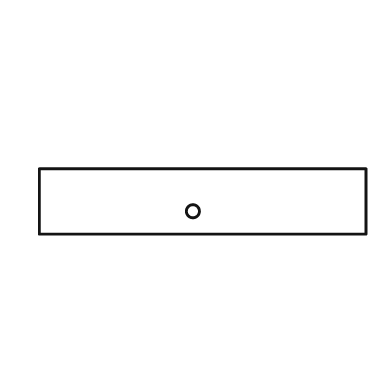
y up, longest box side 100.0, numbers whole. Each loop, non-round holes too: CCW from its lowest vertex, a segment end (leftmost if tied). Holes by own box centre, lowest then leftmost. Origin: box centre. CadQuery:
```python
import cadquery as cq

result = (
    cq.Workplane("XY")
    .moveTo(-50.0, -10.0)
    .lineTo(50.0, -10.0)
    .lineTo(50.0, 10.0)
    .lineTo(-50.0, 10.0)
    .close()
    .moveTo(-3.0, -3.0)
    .circle(2.0)
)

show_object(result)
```